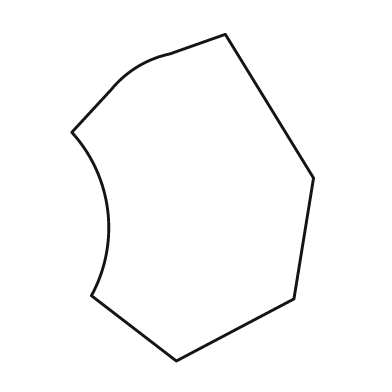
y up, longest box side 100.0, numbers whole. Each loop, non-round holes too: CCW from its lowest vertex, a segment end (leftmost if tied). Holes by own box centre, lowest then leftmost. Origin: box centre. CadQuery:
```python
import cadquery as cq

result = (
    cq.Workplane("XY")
    .moveTo(-5.0, -50.0)
    .lineTo(31.0, -31.0)
    .lineTo(37.0, 6.0)
    .lineTo(10.0, 50.0)
    .lineTo(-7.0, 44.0)
    .threePointArc((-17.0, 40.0), (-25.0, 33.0))
    .lineTo(-37.0, 20.0)
    .threePointArc((-26.0, -4.0), (-31.0, -30.0))
    .close()
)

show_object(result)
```